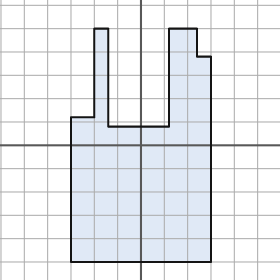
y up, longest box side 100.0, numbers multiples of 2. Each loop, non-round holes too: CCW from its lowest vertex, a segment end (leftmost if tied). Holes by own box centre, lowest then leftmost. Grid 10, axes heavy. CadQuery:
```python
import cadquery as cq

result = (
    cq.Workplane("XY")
    .moveTo(-30.0, -50.0)
    .lineTo(30.0, -50.0)
    .lineTo(30.0, 38.0)
    .lineTo(24.0, 38.0)
    .lineTo(24.0, 50.0)
    .lineTo(12.0, 50.0)
    .lineTo(12.0, 8.0)
    .lineTo(-14.0, 8.0)
    .lineTo(-14.0, 50.0)
    .lineTo(-20.0, 50.0)
    .lineTo(-20.0, 12.0)
    .lineTo(-30.0, 12.0)
    .close()
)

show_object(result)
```